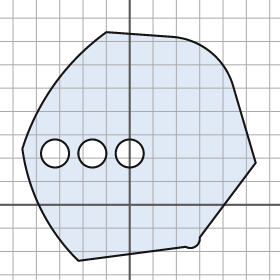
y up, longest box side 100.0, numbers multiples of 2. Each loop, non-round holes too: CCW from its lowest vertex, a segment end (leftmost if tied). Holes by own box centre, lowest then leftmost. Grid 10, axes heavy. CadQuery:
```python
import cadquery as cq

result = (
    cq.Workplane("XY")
    .moveTo(-22.0, -24.0)
    .lineTo(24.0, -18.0)
    .threePointArc((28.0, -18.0), (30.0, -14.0))
    .lineTo(54.0, 18.0)
    .lineTo(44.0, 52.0)
    .threePointArc((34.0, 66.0), (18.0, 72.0))
    .lineTo(-10.0, 74.0)
    .threePointArc((-32.0, 52.0), (-46.0, 24.0))
    .threePointArc((-38.0, -2.0), (-22.0, -24.0))
    .close()
    .moveTo(-32.0, 22.0)
    .circle(6.0)
    .moveTo(-16.0, 22.0)
    .circle(6.0)
    .moveTo(0.0, 22.0)
    .circle(6.0)
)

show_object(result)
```